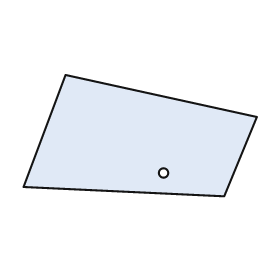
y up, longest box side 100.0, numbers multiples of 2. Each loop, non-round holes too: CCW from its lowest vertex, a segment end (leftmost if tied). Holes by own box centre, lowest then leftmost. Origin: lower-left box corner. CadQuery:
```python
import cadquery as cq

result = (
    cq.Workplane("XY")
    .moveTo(86.0, 0.0)
    .lineTo(100.0, 34.0)
    .lineTo(18.0, 52.0)
    .lineTo(0.0, 4.0)
    .close()
    .moveTo(60.0, 10.0)
    .circle(2.0)
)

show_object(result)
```